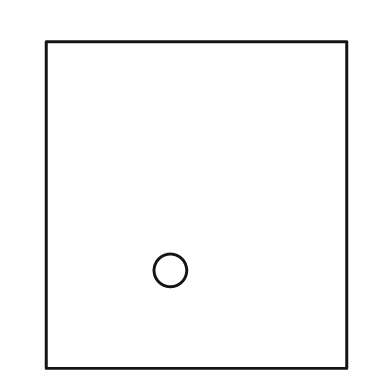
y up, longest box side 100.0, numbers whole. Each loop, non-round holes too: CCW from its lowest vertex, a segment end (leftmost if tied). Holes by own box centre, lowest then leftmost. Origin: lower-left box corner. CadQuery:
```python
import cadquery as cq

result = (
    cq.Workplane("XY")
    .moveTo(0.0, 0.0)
    .lineTo(92.0, 0.0)
    .lineTo(92.0, 100.0)
    .lineTo(0.0, 100.0)
    .close()
    .moveTo(38.0, 30.0)
    .circle(5.0)
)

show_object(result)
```